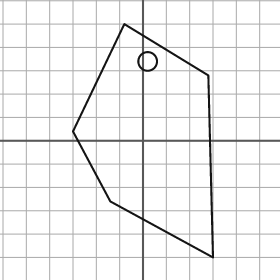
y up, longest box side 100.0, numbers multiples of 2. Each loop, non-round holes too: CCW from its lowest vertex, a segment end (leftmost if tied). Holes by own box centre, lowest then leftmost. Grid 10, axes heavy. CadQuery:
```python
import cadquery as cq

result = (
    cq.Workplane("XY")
    .moveTo(30.0, -50.0)
    .lineTo(28.0, 28.0)
    .lineTo(-8.0, 50.0)
    .lineTo(-30.0, 4.0)
    .lineTo(-14.0, -26.0)
    .close()
    .moveTo(2.0, 34.0)
    .circle(4.0)
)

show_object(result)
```